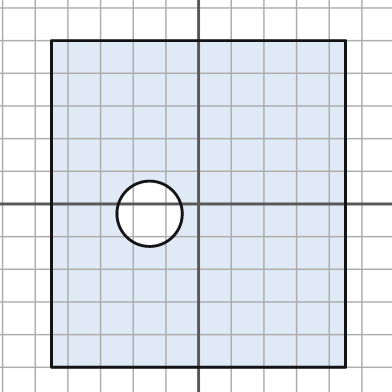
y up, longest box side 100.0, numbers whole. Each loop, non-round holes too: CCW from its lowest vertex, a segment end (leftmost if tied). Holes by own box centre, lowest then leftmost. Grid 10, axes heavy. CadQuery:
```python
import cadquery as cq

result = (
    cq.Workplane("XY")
    .moveTo(-45.0, -50.0)
    .lineTo(45.0, -50.0)
    .lineTo(45.0, 50.0)
    .lineTo(-45.0, 50.0)
    .close()
    .moveTo(-15.0, -3.0)
    .circle(10.0)
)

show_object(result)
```